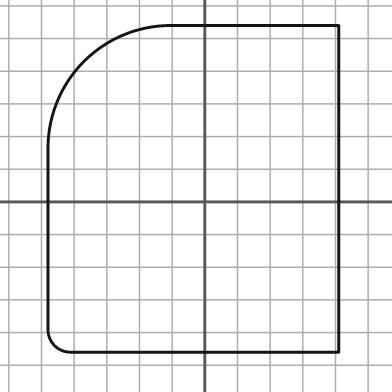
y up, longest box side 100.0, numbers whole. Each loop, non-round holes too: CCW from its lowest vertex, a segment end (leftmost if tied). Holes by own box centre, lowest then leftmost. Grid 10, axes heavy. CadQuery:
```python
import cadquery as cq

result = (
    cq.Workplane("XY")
    .moveTo(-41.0, -46.0)
    .lineTo(41.0, -46.0)
    .lineTo(41.0, 54.0)
    .lineTo(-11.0, 54.0)
    .threePointArc((-37.0, 43.0), (-48.0, 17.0))
    .lineTo(-48.0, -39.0)
    .threePointArc((-46.0, -44.0), (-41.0, -46.0))
    .close()
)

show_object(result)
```